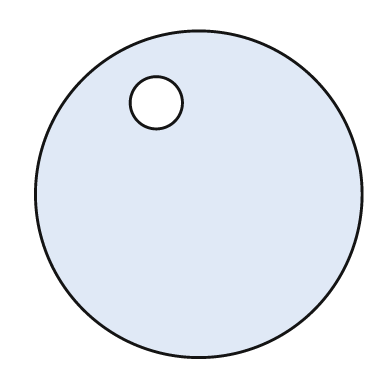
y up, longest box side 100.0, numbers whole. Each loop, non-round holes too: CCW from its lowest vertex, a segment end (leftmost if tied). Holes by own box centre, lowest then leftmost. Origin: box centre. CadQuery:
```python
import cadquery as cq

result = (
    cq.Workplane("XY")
    .moveTo(0.0, 0.0)
    .circle(50.0)
    .moveTo(-13.0, 28.0)
    .circle(8.0)
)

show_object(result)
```